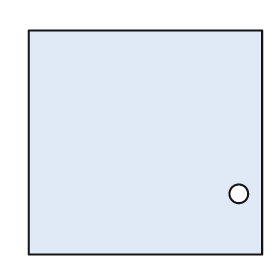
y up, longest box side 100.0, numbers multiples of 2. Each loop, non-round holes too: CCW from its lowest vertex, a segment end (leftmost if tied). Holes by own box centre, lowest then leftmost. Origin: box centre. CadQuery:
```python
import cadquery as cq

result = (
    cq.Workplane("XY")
    .moveTo(-50.0, -48.0)
    .lineTo(50.0, -48.0)
    .lineTo(50.0, 48.0)
    .lineTo(-50.0, 48.0)
    .close()
    .moveTo(40.0, -22.0)
    .circle(4.0)
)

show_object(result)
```